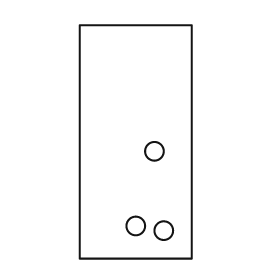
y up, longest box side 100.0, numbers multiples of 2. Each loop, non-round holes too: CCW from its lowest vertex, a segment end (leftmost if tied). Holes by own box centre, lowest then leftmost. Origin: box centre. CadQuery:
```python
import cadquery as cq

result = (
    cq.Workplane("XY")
    .moveTo(-24.0, -50.0)
    .lineTo(24.0, -50.0)
    .lineTo(24.0, 50.0)
    .lineTo(-24.0, 50.0)
    .close()
    .moveTo(12.0, -38.0)
    .circle(4.0)
    .moveTo(0.0, -36.0)
    .circle(4.0)
    .moveTo(8.0, -4.0)
    .circle(4.0)
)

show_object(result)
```